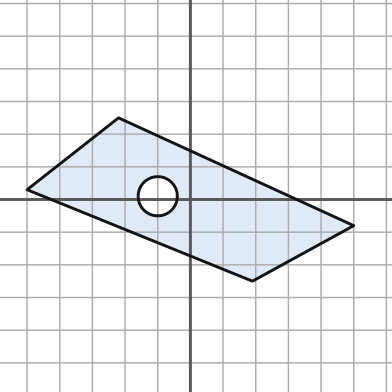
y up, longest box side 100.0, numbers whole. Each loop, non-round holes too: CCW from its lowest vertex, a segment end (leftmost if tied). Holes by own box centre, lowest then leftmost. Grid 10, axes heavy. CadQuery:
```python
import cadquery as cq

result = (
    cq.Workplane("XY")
    .moveTo(19.0, -25.0)
    .lineTo(50.0, -8.0)
    .lineTo(-22.0, 25.0)
    .lineTo(-50.0, 3.0)
    .close()
    .moveTo(-10.0, 1.0)
    .circle(6.0)
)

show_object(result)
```